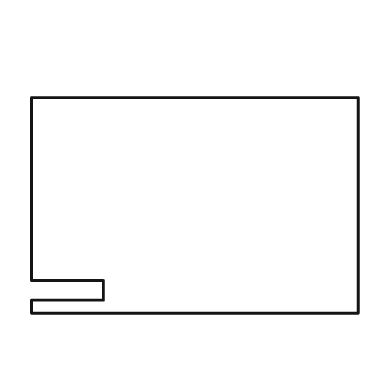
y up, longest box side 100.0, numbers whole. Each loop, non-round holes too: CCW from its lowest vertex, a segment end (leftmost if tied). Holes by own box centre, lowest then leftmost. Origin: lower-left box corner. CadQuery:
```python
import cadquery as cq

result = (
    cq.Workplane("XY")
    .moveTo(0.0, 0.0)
    .lineTo(100.0, 0.0)
    .lineTo(100.0, 66.0)
    .lineTo(0.0, 66.0)
    .lineTo(0.0, 10.0)
    .lineTo(22.0, 10.0)
    .lineTo(22.0, 4.0)
    .lineTo(0.0, 4.0)
    .close()
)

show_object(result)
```